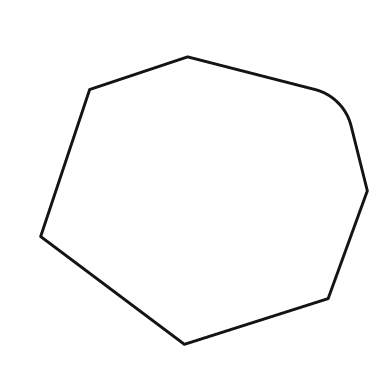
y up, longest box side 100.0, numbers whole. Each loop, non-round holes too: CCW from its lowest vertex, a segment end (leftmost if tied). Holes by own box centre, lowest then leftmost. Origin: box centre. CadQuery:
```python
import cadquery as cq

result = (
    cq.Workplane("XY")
    .moveTo(-6.0, -44.0)
    .lineTo(38.0, -30.0)
    .lineTo(50.0, 3.0)
    .lineTo(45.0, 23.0)
    .threePointArc((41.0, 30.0), (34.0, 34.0))
    .lineTo(-5.0, 44.0)
    .lineTo(-35.0, 34.0)
    .lineTo(-50.0, -11.0)
    .close()
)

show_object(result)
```